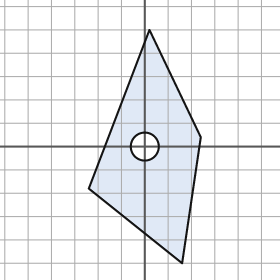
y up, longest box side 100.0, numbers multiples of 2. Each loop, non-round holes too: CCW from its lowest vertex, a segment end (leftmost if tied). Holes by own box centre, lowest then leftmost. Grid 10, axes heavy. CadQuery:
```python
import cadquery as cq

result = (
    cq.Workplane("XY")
    .moveTo(16.0, -50.0)
    .lineTo(24.0, 4.0)
    .lineTo(2.0, 50.0)
    .lineTo(-24.0, -18.0)
    .close()
    .moveTo(0.0, 0.0)
    .circle(6.0)
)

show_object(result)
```